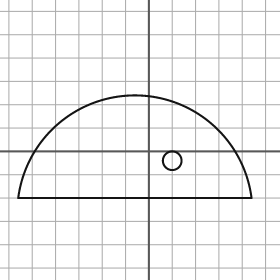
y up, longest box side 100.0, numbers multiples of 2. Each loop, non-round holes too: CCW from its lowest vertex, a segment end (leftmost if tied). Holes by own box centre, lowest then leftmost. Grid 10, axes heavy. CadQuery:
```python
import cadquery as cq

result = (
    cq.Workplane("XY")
    .moveTo(-56.0, -20.0)
    .lineTo(44.0, -20.0)
    .threePointArc((-6.0, 24.0), (-56.0, -20.0))
    .close()
    .moveTo(10.0, -4.0)
    .circle(4.0)
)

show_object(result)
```